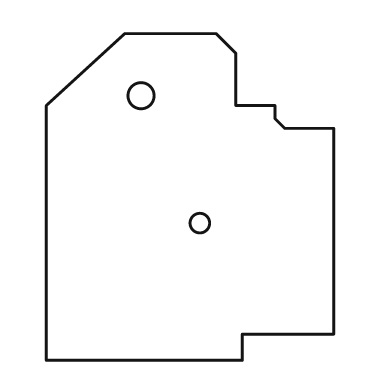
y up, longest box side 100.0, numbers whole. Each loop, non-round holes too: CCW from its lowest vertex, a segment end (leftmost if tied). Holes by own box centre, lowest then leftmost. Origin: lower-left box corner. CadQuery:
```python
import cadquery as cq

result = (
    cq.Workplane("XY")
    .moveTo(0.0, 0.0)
    .lineTo(60.0, 0.0)
    .lineTo(60.0, 8.0)
    .lineTo(88.0, 8.0)
    .lineTo(88.0, 71.0)
    .lineTo(73.0, 71.0)
    .lineTo(70.0, 74.0)
    .lineTo(70.0, 78.0)
    .lineTo(58.0, 78.0)
    .lineTo(58.0, 94.0)
    .lineTo(52.0, 100.0)
    .lineTo(24.0, 100.0)
    .lineTo(0.0, 78.0)
    .close()
    .moveTo(47.0, 42.0)
    .circle(3.0)
    .moveTo(29.0, 81.0)
    .circle(4.0)
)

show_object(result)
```